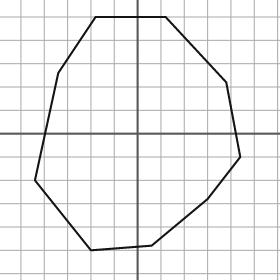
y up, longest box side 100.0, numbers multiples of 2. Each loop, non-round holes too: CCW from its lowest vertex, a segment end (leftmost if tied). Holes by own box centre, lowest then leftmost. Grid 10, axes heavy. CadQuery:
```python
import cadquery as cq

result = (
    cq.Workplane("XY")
    .moveTo(-20.0, -50.0)
    .lineTo(6.0, -48.0)
    .lineTo(30.0, -28.0)
    .lineTo(44.0, -10.0)
    .lineTo(38.0, 22.0)
    .lineTo(12.0, 50.0)
    .lineTo(-18.0, 50.0)
    .lineTo(-34.0, 26.0)
    .lineTo(-44.0, -20.0)
    .close()
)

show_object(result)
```